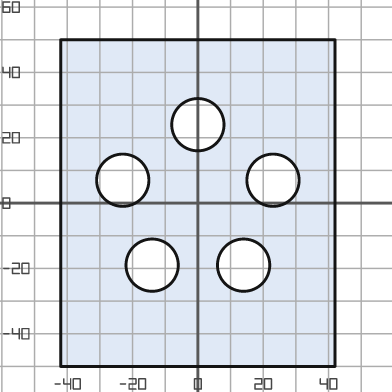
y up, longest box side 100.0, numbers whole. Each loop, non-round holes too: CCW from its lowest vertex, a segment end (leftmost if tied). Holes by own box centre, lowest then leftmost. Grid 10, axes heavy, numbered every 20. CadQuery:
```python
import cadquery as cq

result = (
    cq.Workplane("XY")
    .moveTo(-42.0, -50.0)
    .lineTo(42.0, -50.0)
    .lineTo(42.0, 50.0)
    .lineTo(-42.0, 50.0)
    .close()
    .moveTo(-14.0, -19.0)
    .circle(8.0)
    .moveTo(14.0, -19.0)
    .circle(8.0)
    .moveTo(-23.0, 7.0)
    .circle(8.0)
    .moveTo(23.0, 7.0)
    .circle(8.0)
    .moveTo(0.0, 24.0)
    .circle(8.0)
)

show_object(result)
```